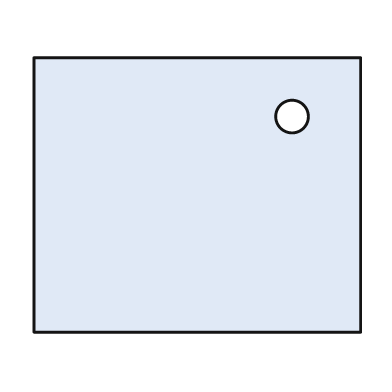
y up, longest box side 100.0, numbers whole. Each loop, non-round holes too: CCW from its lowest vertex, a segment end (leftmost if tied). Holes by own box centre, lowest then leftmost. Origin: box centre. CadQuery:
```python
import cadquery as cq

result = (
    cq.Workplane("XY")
    .moveTo(-50.0, -42.0)
    .lineTo(50.0, -42.0)
    .lineTo(50.0, 42.0)
    .lineTo(-50.0, 42.0)
    .close()
    .moveTo(29.0, 24.0)
    .circle(5.0)
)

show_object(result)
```